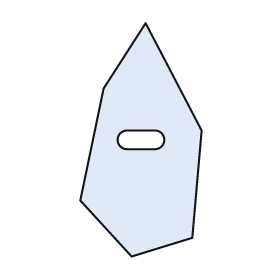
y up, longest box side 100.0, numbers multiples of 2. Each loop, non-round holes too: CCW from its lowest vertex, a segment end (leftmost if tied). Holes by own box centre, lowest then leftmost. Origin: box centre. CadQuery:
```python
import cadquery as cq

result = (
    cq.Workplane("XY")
    .moveTo(-4.0, -50.0)
    .lineTo(22.0, -42.0)
    .lineTo(26.0, 4.0)
    .lineTo(2.0, 50.0)
    .lineTo(-16.0, 22.0)
    .lineTo(-26.0, -26.0)
    .close()
    .moveTo(-6.0, -4.0)
    .lineTo(6.0, -4.0)
    .threePointArc((10.0, 0.0), (6.0, 4.0))
    .lineTo(-6.0, 4.0)
    .threePointArc((-10.0, 0.0), (-6.0, -4.0))
    .close()
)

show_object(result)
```